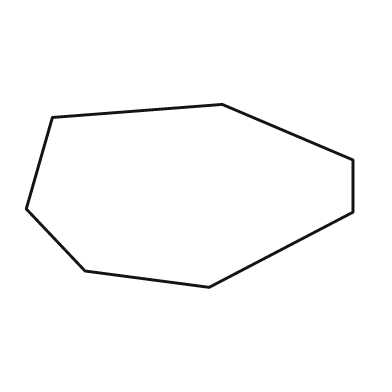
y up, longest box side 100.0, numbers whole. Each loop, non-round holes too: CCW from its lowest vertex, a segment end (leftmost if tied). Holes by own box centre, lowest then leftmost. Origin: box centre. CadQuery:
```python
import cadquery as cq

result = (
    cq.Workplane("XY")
    .moveTo(6.0, -28.0)
    .lineTo(50.0, -5.0)
    .lineTo(50.0, 11.0)
    .lineTo(10.0, 28.0)
    .lineTo(-42.0, 24.0)
    .lineTo(-50.0, -4.0)
    .lineTo(-32.0, -23.0)
    .close()
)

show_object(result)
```